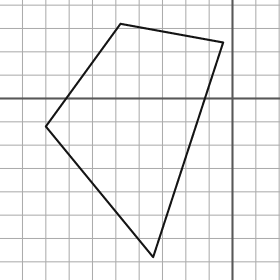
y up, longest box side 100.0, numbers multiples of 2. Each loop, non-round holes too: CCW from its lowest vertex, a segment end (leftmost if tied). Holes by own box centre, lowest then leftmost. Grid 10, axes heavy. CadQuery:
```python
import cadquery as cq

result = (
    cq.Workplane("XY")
    .moveTo(-34.0, -68.0)
    .lineTo(-4.0, 24.0)
    .lineTo(-48.0, 32.0)
    .lineTo(-80.0, -12.0)
    .close()
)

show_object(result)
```